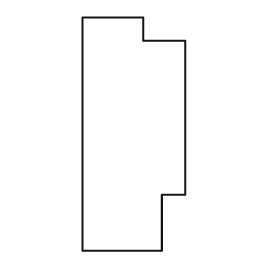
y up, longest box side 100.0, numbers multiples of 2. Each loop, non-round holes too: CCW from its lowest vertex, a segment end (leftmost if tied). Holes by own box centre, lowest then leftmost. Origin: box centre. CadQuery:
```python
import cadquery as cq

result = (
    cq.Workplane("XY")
    .moveTo(-22.0, -50.0)
    .lineTo(12.0, -50.0)
    .lineTo(12.0, -26.0)
    .lineTo(22.0, -26.0)
    .lineTo(22.0, 40.0)
    .lineTo(4.0, 40.0)
    .lineTo(4.0, 50.0)
    .lineTo(-22.0, 50.0)
    .close()
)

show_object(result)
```